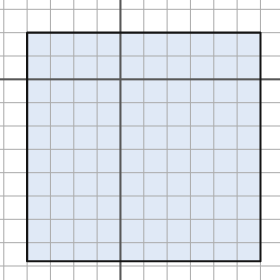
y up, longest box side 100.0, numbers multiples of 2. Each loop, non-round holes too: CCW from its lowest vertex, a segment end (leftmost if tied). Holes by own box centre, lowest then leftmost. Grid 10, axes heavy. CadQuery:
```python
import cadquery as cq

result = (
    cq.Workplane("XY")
    .moveTo(-40.0, -78.0)
    .lineTo(60.0, -78.0)
    .lineTo(60.0, 20.0)
    .lineTo(-40.0, 20.0)
    .close()
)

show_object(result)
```